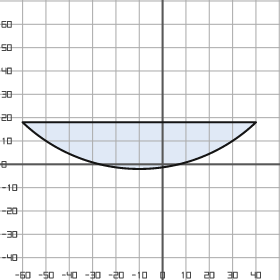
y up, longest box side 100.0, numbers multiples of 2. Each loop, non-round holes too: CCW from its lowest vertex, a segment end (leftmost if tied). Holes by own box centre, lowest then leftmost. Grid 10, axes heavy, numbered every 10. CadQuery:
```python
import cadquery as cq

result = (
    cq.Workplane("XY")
    .moveTo(-60.0, 18.0)
    .threePointArc((-10.0, -2.0), (40.0, 18.0))
    .close()
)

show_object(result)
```